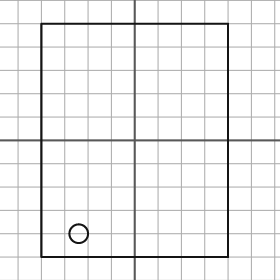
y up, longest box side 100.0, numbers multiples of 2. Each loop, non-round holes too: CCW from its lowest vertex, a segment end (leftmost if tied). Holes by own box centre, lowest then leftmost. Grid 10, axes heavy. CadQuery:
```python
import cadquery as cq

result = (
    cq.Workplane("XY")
    .moveTo(-40.0, -50.0)
    .lineTo(40.0, -50.0)
    .lineTo(40.0, 50.0)
    .lineTo(-40.0, 50.0)
    .close()
    .moveTo(-24.0, -40.0)
    .circle(4.0)
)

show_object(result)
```